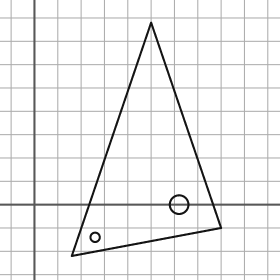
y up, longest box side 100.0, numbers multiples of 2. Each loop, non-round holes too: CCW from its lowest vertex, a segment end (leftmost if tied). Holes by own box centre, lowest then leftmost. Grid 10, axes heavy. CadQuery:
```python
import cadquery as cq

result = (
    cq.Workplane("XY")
    .moveTo(16.0, -22.0)
    .lineTo(80.0, -10.0)
    .lineTo(50.0, 78.0)
    .close()
    .moveTo(26.0, -14.0)
    .circle(2.0)
    .moveTo(62.0, 0.0)
    .circle(4.0)
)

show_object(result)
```